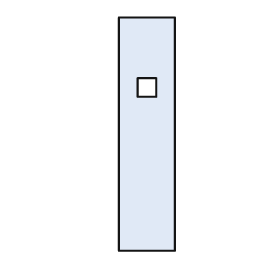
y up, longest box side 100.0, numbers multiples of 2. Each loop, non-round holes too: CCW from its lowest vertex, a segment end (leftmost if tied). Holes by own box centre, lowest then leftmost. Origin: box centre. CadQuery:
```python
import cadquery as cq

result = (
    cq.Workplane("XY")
    .moveTo(-12.0, -50.0)
    .lineTo(12.0, -50.0)
    .lineTo(12.0, 50.0)
    .lineTo(-12.0, 50.0)
    .close()
    .moveTo(-4.0, 16.0)
    .lineTo(4.0, 16.0)
    .lineTo(4.0, 24.0)
    .lineTo(-4.0, 24.0)
    .close()
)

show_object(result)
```